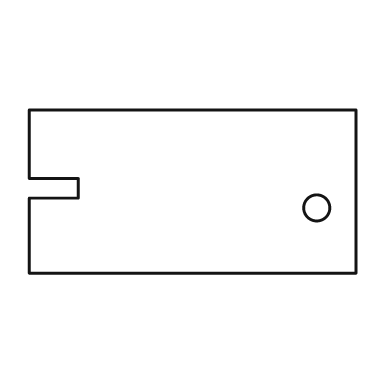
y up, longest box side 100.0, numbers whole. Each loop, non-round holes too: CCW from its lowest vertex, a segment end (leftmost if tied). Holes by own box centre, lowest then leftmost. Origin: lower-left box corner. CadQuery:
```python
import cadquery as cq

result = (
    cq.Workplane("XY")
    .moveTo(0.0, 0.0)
    .lineTo(100.0, 0.0)
    .lineTo(100.0, 50.0)
    .lineTo(0.0, 50.0)
    .lineTo(0.0, 29.0)
    .lineTo(15.0, 29.0)
    .lineTo(15.0, 23.0)
    .lineTo(0.0, 23.0)
    .close()
    .moveTo(88.0, 20.0)
    .circle(4.0)
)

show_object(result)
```